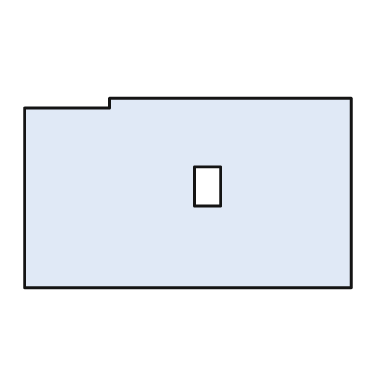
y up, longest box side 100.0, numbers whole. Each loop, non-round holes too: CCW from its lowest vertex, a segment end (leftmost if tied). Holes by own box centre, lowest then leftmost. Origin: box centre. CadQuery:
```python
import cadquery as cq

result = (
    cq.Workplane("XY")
    .moveTo(-50.0, -29.0)
    .lineTo(50.0, -29.0)
    .lineTo(50.0, 29.0)
    .lineTo(-24.0, 29.0)
    .lineTo(-24.0, 26.0)
    .lineTo(-50.0, 26.0)
    .close()
    .moveTo(2.0, -4.0)
    .lineTo(10.0, -4.0)
    .lineTo(10.0, 8.0)
    .lineTo(2.0, 8.0)
    .close()
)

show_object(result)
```